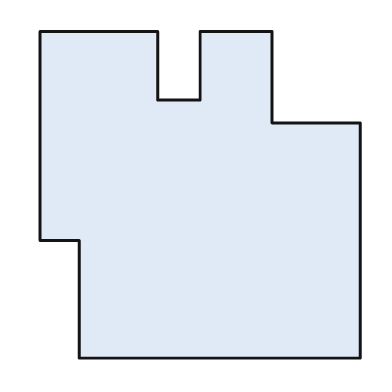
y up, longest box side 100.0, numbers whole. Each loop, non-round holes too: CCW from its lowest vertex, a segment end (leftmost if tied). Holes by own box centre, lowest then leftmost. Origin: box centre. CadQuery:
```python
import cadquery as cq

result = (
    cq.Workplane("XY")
    .moveTo(-37.0, -50.0)
    .lineTo(49.0, -50.0)
    .lineTo(49.0, 22.0)
    .lineTo(22.0, 22.0)
    .lineTo(22.0, 50.0)
    .lineTo(0.0, 50.0)
    .lineTo(0.0, 29.0)
    .lineTo(-13.0, 29.0)
    .lineTo(-13.0, 50.0)
    .lineTo(-49.0, 50.0)
    .lineTo(-49.0, -14.0)
    .lineTo(-37.0, -14.0)
    .close()
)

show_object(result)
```